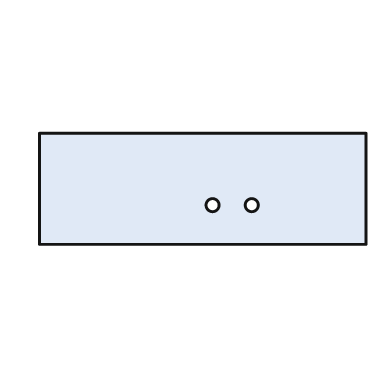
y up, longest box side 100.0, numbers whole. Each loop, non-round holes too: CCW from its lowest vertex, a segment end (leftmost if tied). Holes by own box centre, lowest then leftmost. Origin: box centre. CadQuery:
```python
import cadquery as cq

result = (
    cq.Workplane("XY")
    .moveTo(-50.0, -17.0)
    .lineTo(50.0, -17.0)
    .lineTo(50.0, 17.0)
    .lineTo(-50.0, 17.0)
    .close()
    .moveTo(3.0, -5.0)
    .circle(2.0)
    .moveTo(15.0, -5.0)
    .circle(2.0)
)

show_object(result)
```